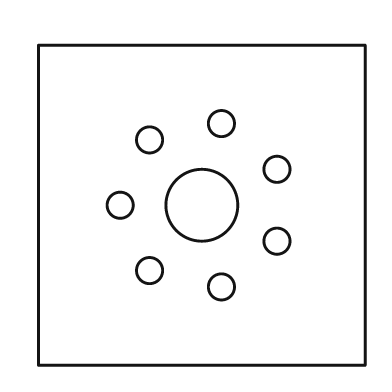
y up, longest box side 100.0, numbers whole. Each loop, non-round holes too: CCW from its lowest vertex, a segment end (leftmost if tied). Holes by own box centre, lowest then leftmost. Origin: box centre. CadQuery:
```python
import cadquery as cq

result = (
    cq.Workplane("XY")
    .moveTo(-50.0, -49.0)
    .lineTo(50.0, -49.0)
    .lineTo(50.0, 49.0)
    .lineTo(-50.0, 49.0)
    .close()
    .moveTo(6.0, -25.0)
    .circle(4.0)
    .moveTo(-16.0, -20.0)
    .circle(4.0)
    .moveTo(23.0, -11.0)
    .circle(4.0)
    .moveTo(-25.0, 0.0)
    .circle(4.0)
    .moveTo(0.0, 0.0)
    .circle(11.0)
    .moveTo(23.0, 11.0)
    .circle(4.0)
    .moveTo(-16.0, 20.0)
    .circle(4.0)
    .moveTo(6.0, 25.0)
    .circle(4.0)
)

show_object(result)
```